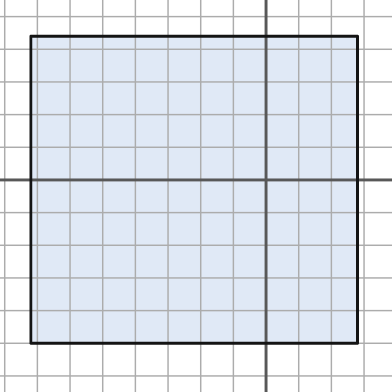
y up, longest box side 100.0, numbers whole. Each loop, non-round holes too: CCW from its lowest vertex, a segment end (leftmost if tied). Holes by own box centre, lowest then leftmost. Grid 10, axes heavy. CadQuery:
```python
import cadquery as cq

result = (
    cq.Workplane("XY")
    .moveTo(-72.0, -50.0)
    .lineTo(28.0, -50.0)
    .lineTo(28.0, 44.0)
    .lineTo(-72.0, 44.0)
    .close()
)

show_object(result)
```